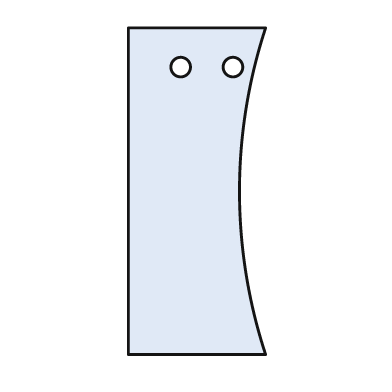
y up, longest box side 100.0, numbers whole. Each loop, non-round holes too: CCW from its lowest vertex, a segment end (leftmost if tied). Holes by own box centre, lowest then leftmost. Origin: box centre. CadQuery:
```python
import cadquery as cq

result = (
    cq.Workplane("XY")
    .moveTo(-21.0, -50.0)
    .lineTo(21.0, -50.0)
    .threePointArc((13.0, 0.0), (21.0, 50.0))
    .lineTo(-21.0, 50.0)
    .close()
    .moveTo(-5.0, 38.0)
    .circle(3.0)
    .moveTo(11.0, 38.0)
    .circle(3.0)
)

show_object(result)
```